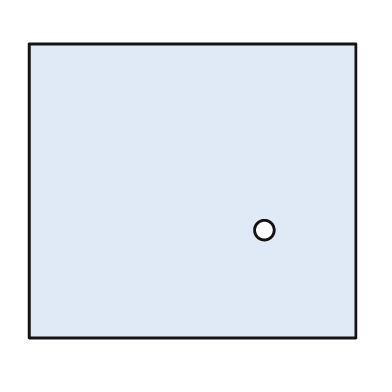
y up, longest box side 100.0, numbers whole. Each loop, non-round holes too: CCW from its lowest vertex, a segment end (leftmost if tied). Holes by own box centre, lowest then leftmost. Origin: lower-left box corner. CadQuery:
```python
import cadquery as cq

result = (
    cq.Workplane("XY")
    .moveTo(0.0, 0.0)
    .lineTo(100.0, 0.0)
    .lineTo(100.0, 90.0)
    .lineTo(0.0, 90.0)
    .close()
    .moveTo(72.0, 33.0)
    .circle(3.0)
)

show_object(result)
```